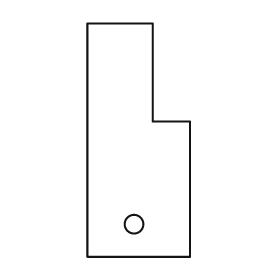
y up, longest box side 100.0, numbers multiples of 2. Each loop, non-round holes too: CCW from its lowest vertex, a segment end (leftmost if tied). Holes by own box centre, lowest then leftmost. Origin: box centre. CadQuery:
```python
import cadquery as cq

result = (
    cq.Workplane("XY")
    .moveTo(-22.0, -50.0)
    .lineTo(22.0, -50.0)
    .lineTo(22.0, 8.0)
    .lineTo(6.0, 8.0)
    .lineTo(6.0, 50.0)
    .lineTo(-22.0, 50.0)
    .close()
    .moveTo(-2.0, -36.0)
    .circle(4.0)
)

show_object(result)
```